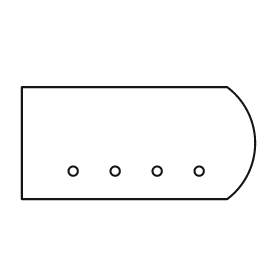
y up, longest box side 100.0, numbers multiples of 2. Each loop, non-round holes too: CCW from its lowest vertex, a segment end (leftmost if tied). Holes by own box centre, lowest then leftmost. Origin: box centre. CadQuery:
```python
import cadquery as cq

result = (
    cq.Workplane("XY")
    .moveTo(-50.0, -24.0)
    .lineTo(38.0, -24.0)
    .threePointArc((50.0, 0.0), (38.0, 24.0))
    .lineTo(-50.0, 24.0)
    .close()
    .moveTo(-28.0, -12.0)
    .circle(2.0)
    .moveTo(-10.0, -12.0)
    .circle(2.0)
    .moveTo(8.0, -12.0)
    .circle(2.0)
    .moveTo(26.0, -12.0)
    .circle(2.0)
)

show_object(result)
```